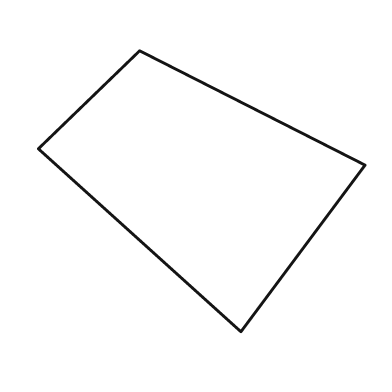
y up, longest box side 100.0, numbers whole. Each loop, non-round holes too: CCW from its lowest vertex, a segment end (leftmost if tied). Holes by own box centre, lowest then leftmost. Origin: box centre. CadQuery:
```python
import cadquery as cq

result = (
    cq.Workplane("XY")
    .moveTo(12.0, -43.0)
    .lineTo(50.0, 8.0)
    .lineTo(-19.0, 43.0)
    .lineTo(-50.0, 13.0)
    .close()
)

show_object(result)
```